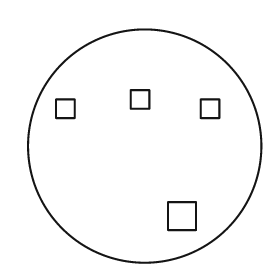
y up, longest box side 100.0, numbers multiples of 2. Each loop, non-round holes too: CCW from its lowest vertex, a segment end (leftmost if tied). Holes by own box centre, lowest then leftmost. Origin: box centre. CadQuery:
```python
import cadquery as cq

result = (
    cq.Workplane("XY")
    .moveTo(0.0, 0.0)
    .circle(50.0)
    .moveTo(10.0, -36.0)
    .lineTo(22.0, -36.0)
    .lineTo(22.0, -24.0)
    .lineTo(10.0, -24.0)
    .close()
    .moveTo(-38.0, 12.0)
    .lineTo(-30.0, 12.0)
    .lineTo(-30.0, 20.0)
    .lineTo(-38.0, 20.0)
    .close()
    .moveTo(24.0, 12.0)
    .lineTo(32.0, 12.0)
    .lineTo(32.0, 20.0)
    .lineTo(24.0, 20.0)
    .close()
    .moveTo(-6.0, 16.0)
    .lineTo(2.0, 16.0)
    .lineTo(2.0, 24.0)
    .lineTo(-6.0, 24.0)
    .close()
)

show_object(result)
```